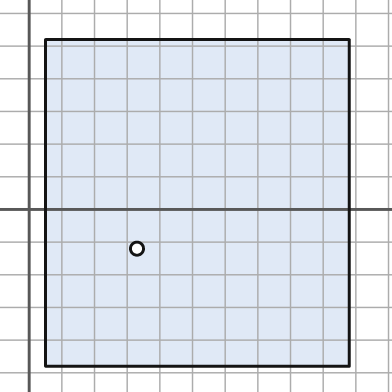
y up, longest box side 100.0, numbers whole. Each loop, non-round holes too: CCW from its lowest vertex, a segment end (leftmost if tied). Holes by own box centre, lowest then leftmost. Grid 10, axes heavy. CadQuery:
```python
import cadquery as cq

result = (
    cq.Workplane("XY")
    .moveTo(5.0, -48.0)
    .lineTo(98.0, -48.0)
    .lineTo(98.0, 52.0)
    .lineTo(5.0, 52.0)
    .close()
    .moveTo(33.0, -12.0)
    .circle(2.0)
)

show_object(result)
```